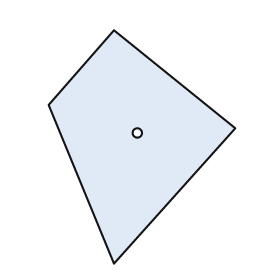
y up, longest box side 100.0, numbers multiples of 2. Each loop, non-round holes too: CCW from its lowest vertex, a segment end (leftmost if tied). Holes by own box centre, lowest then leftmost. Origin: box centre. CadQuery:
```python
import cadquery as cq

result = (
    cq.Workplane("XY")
    .moveTo(-12.0, -50.0)
    .lineTo(40.0, 8.0)
    .lineTo(-12.0, 50.0)
    .lineTo(-40.0, 18.0)
    .close()
    .moveTo(-2.0, 6.0)
    .circle(2.0)
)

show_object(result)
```